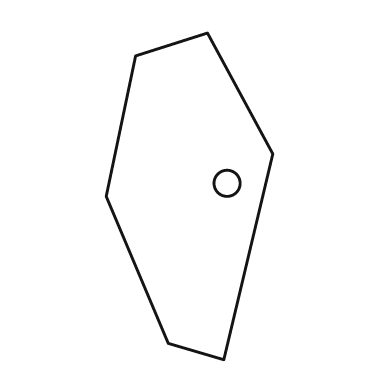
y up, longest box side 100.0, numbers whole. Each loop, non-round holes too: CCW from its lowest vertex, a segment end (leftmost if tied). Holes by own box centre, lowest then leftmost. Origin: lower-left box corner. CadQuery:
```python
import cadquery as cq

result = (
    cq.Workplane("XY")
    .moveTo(36.0, 0.0)
    .lineTo(51.0, 63.0)
    .lineTo(31.0, 100.0)
    .lineTo(9.0, 93.0)
    .lineTo(0.0, 50.0)
    .lineTo(19.0, 5.0)
    .close()
    .moveTo(37.0, 54.0)
    .circle(4.0)
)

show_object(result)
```